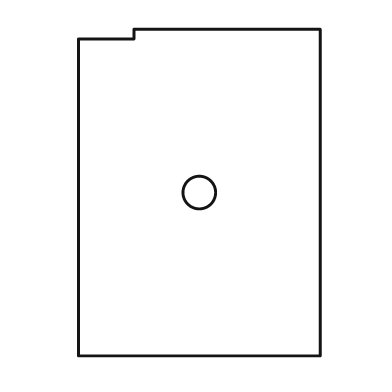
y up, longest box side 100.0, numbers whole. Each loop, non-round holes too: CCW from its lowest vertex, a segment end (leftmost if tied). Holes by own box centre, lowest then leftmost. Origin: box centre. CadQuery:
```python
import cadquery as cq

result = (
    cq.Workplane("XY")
    .moveTo(-37.0, -50.0)
    .lineTo(37.0, -50.0)
    .lineTo(37.0, 50.0)
    .lineTo(-20.0, 50.0)
    .lineTo(-20.0, 47.0)
    .lineTo(-37.0, 47.0)
    .close()
    .moveTo(0.0, 0.0)
    .circle(5.0)
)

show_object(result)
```